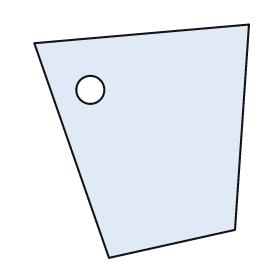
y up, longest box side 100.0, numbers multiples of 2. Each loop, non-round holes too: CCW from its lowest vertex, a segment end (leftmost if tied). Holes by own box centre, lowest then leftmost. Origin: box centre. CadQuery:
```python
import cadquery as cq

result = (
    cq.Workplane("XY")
    .moveTo(-14.0, -50.0)
    .lineTo(40.0, -38.0)
    .lineTo(46.0, 50.0)
    .lineTo(-46.0, 42.0)
    .close()
    .moveTo(-22.0, 22.0)
    .circle(6.0)
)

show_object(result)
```